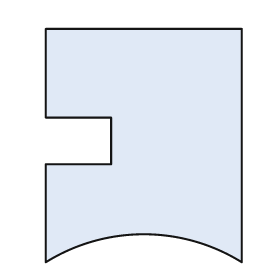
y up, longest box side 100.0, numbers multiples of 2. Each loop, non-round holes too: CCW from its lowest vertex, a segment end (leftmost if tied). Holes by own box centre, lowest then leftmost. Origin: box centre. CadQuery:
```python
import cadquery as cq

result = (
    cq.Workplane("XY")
    .moveTo(-42.0, -50.0)
    .threePointArc((0.0, -38.0), (42.0, -50.0))
    .lineTo(42.0, 50.0)
    .lineTo(-42.0, 50.0)
    .lineTo(-42.0, 12.0)
    .lineTo(-14.0, 12.0)
    .lineTo(-14.0, -8.0)
    .lineTo(-42.0, -8.0)
    .close()
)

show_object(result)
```